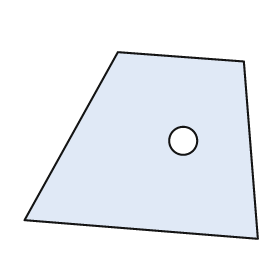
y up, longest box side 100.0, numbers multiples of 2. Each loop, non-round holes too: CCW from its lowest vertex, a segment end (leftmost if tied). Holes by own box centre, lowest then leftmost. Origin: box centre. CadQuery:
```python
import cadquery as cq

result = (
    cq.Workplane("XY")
    .moveTo(50.0, -40.0)
    .lineTo(44.0, 36.0)
    .lineTo(-10.0, 40.0)
    .lineTo(-50.0, -32.0)
    .close()
    .moveTo(18.0, 2.0)
    .circle(6.0)
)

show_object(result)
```